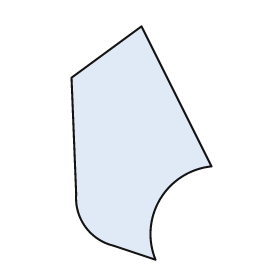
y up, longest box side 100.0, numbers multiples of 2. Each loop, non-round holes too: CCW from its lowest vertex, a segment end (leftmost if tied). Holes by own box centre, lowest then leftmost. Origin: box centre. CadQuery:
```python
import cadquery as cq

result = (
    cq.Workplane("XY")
    .moveTo(6.0, -50.0)
    .threePointArc((8.0, -24.0), (30.0, -10.0))
    .lineTo(0.0, 50.0)
    .lineTo(-30.0, 28.0)
    .lineTo(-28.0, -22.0)
    .threePointArc((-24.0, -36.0), (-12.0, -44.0))
    .close()
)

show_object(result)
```